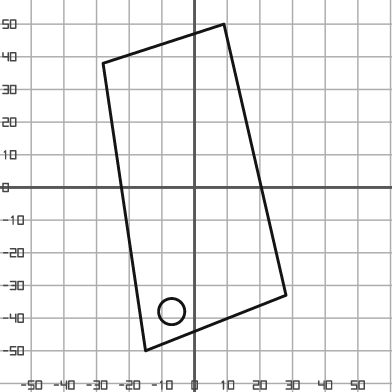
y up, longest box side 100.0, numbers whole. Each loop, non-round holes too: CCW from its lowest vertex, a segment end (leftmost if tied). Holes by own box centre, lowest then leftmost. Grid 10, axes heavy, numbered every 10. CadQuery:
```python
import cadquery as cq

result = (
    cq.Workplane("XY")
    .moveTo(-15.0, -50.0)
    .lineTo(28.0, -33.0)
    .lineTo(9.0, 50.0)
    .lineTo(-28.0, 38.0)
    .close()
    .moveTo(-7.0, -38.0)
    .circle(4.0)
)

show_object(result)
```